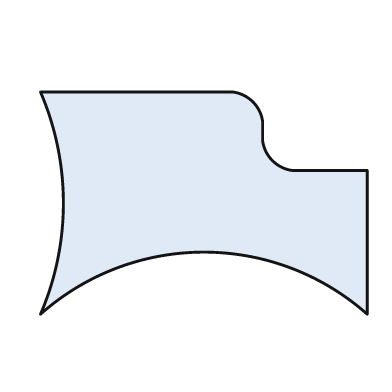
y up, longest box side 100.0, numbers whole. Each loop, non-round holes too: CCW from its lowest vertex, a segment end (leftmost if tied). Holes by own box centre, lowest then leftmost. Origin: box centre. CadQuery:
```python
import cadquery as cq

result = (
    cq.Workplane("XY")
    .moveTo(-50.0, -34.0)
    .threePointArc((0.0, -15.0), (50.0, -34.0))
    .lineTo(50.0, 10.0)
    .lineTo(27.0, 10.0)
    .threePointArc((21.0, 13.0), (18.0, 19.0))
    .lineTo(18.0, 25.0)
    .threePointArc((15.0, 31.0), (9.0, 34.0))
    .lineTo(-50.0, 34.0)
    .threePointArc((-43.0, 0.0), (-50.0, -34.0))
    .close()
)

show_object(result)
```